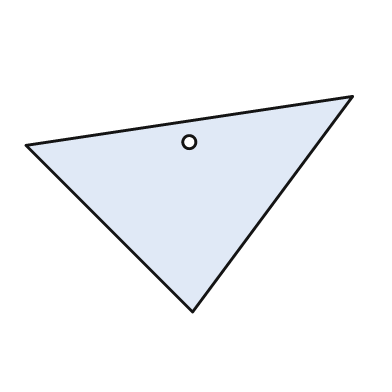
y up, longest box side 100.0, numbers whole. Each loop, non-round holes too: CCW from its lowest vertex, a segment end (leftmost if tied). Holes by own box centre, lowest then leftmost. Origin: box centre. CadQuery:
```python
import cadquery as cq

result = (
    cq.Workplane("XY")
    .moveTo(1.0, -33.0)
    .lineTo(50.0, 33.0)
    .lineTo(-50.0, 18.0)
    .close()
    .moveTo(0.0, 19.0)
    .circle(2.0)
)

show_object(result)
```